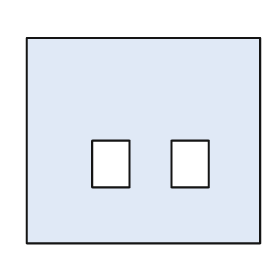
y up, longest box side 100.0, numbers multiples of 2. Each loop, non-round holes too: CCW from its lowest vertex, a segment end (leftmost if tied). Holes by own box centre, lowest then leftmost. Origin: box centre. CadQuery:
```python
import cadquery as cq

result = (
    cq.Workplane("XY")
    .moveTo(-50.0, -44.0)
    .lineTo(50.0, -44.0)
    .lineTo(50.0, 44.0)
    .lineTo(-50.0, 44.0)
    .close()
    .moveTo(-22.0, -20.0)
    .lineTo(-6.0, -20.0)
    .lineTo(-6.0, 0.0)
    .lineTo(-22.0, 0.0)
    .close()
    .moveTo(12.0, -20.0)
    .lineTo(28.0, -20.0)
    .lineTo(28.0, 0.0)
    .lineTo(12.0, 0.0)
    .close()
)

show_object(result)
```